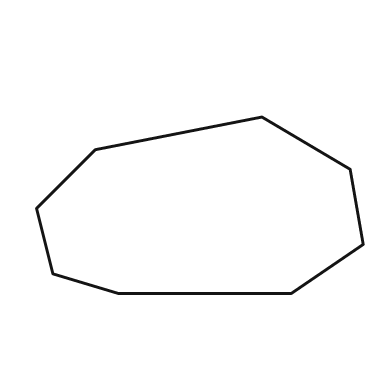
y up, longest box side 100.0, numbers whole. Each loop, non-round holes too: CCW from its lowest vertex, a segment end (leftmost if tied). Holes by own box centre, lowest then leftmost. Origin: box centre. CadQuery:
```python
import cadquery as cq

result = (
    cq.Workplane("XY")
    .moveTo(-25.0, -27.0)
    .lineTo(28.0, -27.0)
    .lineTo(50.0, -12.0)
    .lineTo(46.0, 11.0)
    .lineTo(19.0, 27.0)
    .lineTo(-32.0, 17.0)
    .lineTo(-50.0, -1.0)
    .lineTo(-45.0, -21.0)
    .close()
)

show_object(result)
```